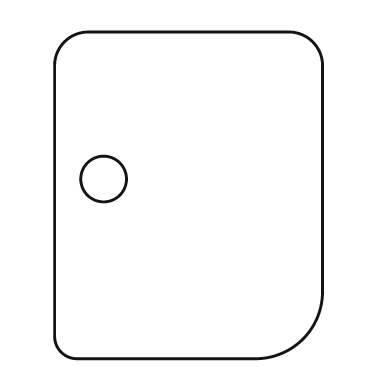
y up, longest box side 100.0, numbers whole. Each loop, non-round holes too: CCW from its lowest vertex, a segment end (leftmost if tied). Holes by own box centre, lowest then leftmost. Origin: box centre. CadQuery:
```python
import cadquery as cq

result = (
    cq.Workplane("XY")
    .moveTo(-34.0, -50.0)
    .lineTo(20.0, -50.0)
    .threePointArc((35.0, -44.0), (41.0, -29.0))
    .lineTo(41.0, 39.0)
    .threePointArc((38.0, 47.0), (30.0, 50.0))
    .lineTo(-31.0, 50.0)
    .threePointArc((-38.0, 47.0), (-41.0, 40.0))
    .lineTo(-41.0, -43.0)
    .threePointArc((-39.0, -48.0), (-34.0, -50.0))
    .close()
    .moveTo(-26.0, 5.0)
    .circle(7.0)
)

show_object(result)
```